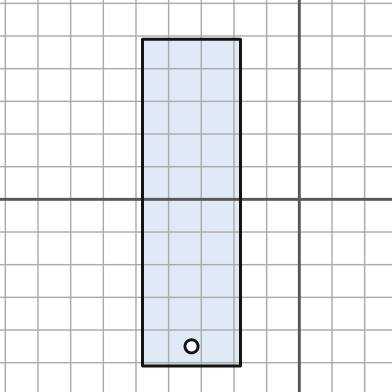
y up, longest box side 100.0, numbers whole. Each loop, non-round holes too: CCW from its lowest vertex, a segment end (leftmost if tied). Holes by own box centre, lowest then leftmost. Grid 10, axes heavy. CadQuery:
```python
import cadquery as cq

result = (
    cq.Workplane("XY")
    .moveTo(-48.0, -51.0)
    .lineTo(-18.0, -51.0)
    .lineTo(-18.0, 49.0)
    .lineTo(-48.0, 49.0)
    .close()
    .moveTo(-33.0, -45.0)
    .circle(2.0)
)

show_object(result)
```